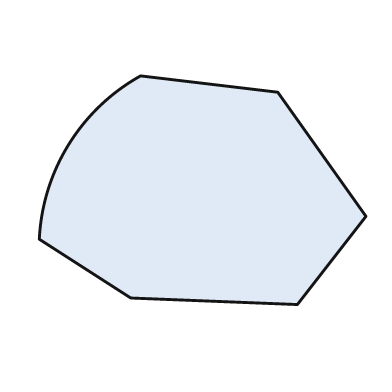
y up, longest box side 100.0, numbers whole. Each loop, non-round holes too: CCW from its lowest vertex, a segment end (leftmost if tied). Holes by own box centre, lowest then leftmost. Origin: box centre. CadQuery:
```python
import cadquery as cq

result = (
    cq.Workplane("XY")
    .moveTo(29.0, -35.0)
    .lineTo(50.0, -8.0)
    .lineTo(23.0, 30.0)
    .lineTo(-19.0, 35.0)
    .threePointArc((-41.0, 14.0), (-50.0, -15.0))
    .lineTo(-22.0, -33.0)
    .close()
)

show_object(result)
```